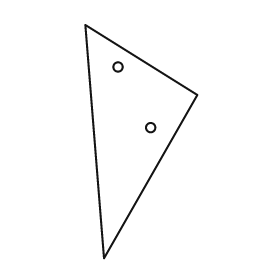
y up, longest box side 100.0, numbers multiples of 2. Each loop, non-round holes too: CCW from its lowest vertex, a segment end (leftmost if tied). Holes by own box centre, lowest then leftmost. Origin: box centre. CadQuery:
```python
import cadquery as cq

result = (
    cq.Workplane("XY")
    .moveTo(-16.0, -50.0)
    .lineTo(24.0, 20.0)
    .lineTo(-24.0, 50.0)
    .close()
    .moveTo(4.0, 6.0)
    .circle(2.0)
    .moveTo(-10.0, 32.0)
    .circle(2.0)
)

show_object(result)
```